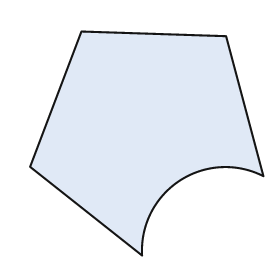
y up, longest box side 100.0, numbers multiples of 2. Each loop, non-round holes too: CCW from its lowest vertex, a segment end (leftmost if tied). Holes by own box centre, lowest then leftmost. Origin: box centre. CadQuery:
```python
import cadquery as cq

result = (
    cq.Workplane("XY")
    .moveTo(-2.0, -48.0)
    .threePointArc((14.0, -16.0), (50.0, -14.0))
    .lineTo(34.0, 46.0)
    .lineTo(-28.0, 48.0)
    .lineTo(-50.0, -10.0)
    .close()
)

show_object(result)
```